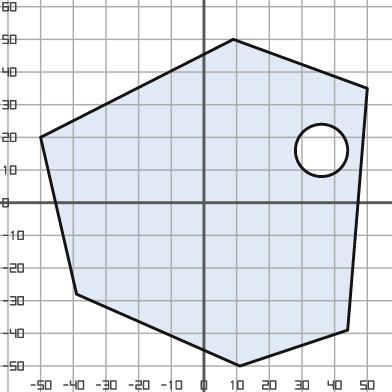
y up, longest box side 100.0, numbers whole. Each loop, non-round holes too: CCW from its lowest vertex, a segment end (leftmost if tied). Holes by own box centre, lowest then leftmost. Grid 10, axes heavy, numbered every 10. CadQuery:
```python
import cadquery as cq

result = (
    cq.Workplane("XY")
    .moveTo(11.0, -50.0)
    .lineTo(44.0, -39.0)
    .lineTo(50.0, 35.0)
    .lineTo(9.0, 50.0)
    .lineTo(-50.0, 20.0)
    .lineTo(-39.0, -28.0)
    .close()
    .moveTo(36.0, 16.0)
    .circle(8.0)
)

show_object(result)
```